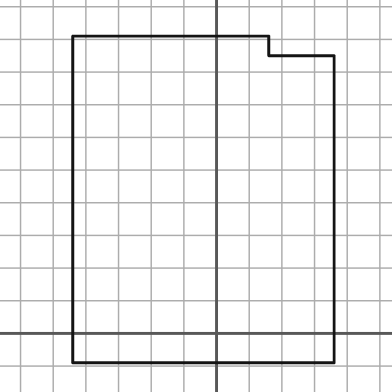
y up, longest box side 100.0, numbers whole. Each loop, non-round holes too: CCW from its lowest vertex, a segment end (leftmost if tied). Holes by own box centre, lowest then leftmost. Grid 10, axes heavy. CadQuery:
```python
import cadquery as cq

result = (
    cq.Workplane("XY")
    .moveTo(-44.0, -9.0)
    .lineTo(36.0, -9.0)
    .lineTo(36.0, 85.0)
    .lineTo(16.0, 85.0)
    .lineTo(16.0, 91.0)
    .lineTo(-44.0, 91.0)
    .close()
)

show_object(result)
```